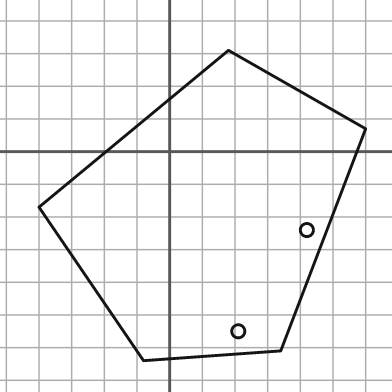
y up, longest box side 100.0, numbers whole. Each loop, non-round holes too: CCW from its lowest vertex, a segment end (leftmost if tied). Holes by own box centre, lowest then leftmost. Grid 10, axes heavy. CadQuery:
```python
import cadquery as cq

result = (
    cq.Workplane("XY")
    .moveTo(-8.0, -64.0)
    .lineTo(34.0, -61.0)
    .lineTo(60.0, 7.0)
    .lineTo(18.0, 31.0)
    .lineTo(-40.0, -17.0)
    .close()
    .moveTo(21.0, -55.0)
    .circle(2.0)
    .moveTo(42.0, -24.0)
    .circle(2.0)
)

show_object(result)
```